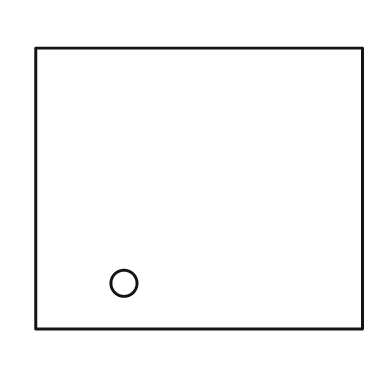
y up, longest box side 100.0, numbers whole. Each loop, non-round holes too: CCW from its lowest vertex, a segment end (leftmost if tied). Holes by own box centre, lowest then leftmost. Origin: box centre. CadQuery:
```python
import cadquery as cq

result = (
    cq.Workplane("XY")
    .moveTo(-50.0, -43.0)
    .lineTo(50.0, -43.0)
    .lineTo(50.0, 43.0)
    .lineTo(-50.0, 43.0)
    .close()
    .moveTo(-23.0, -29.0)
    .circle(4.0)
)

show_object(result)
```